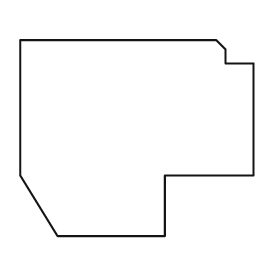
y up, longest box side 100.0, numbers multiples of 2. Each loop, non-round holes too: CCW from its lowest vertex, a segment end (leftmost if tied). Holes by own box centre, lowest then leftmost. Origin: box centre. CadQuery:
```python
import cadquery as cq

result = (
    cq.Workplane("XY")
    .moveTo(-34.0, -42.0)
    .lineTo(12.0, -42.0)
    .lineTo(12.0, -16.0)
    .lineTo(50.0, -16.0)
    .lineTo(50.0, 32.0)
    .lineTo(38.0, 32.0)
    .lineTo(38.0, 38.0)
    .lineTo(34.0, 42.0)
    .lineTo(-50.0, 42.0)
    .lineTo(-50.0, -16.0)
    .close()
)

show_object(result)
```